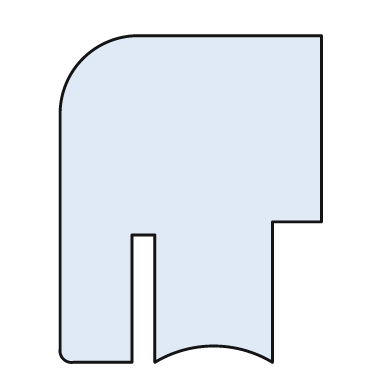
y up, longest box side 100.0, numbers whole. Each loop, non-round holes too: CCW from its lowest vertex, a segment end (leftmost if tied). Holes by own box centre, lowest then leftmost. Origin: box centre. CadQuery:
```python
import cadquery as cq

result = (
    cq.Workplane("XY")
    .moveTo(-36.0, -50.0)
    .lineTo(-18.0, -50.0)
    .lineTo(-18.0, -11.0)
    .lineTo(-11.0, -11.0)
    .lineTo(-11.0, -50.0)
    .threePointArc((7.0, -45.0), (25.0, -50.0))
    .lineTo(25.0, -7.0)
    .lineTo(40.0, -7.0)
    .lineTo(40.0, 50.0)
    .lineTo(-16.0, 50.0)
    .threePointArc((-33.0, 43.0), (-40.0, 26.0))
    .lineTo(-40.0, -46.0)
    .threePointArc((-39.0, -49.0), (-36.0, -50.0))
    .close()
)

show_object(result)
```